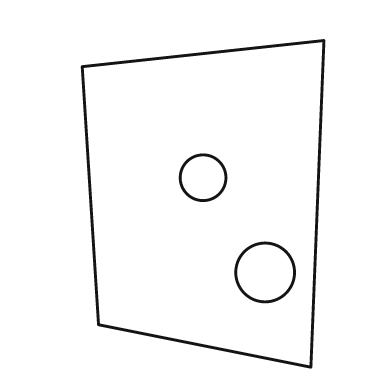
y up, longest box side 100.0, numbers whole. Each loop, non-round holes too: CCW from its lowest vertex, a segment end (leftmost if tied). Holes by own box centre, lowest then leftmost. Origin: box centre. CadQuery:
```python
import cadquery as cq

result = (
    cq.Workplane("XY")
    .moveTo(33.0, -50.0)
    .lineTo(37.0, 50.0)
    .lineTo(-37.0, 42.0)
    .lineTo(-32.0, -37.0)
    .close()
    .moveTo(19.0, -21.0)
    .circle(9.0)
    .moveTo(0.0, 8.0)
    .circle(7.0)
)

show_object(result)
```